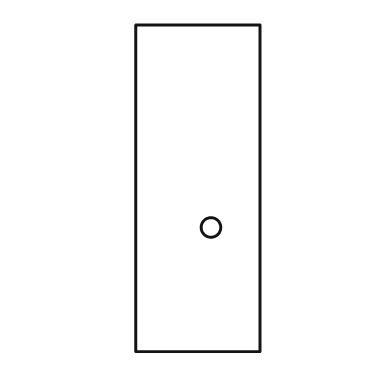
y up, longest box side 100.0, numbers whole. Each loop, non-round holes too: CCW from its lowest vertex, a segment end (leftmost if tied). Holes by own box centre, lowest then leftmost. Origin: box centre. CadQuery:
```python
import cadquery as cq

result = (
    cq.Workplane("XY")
    .moveTo(-19.0, -50.0)
    .lineTo(19.0, -50.0)
    .lineTo(19.0, 50.0)
    .lineTo(-19.0, 50.0)
    .close()
    .moveTo(4.0, -12.0)
    .circle(3.0)
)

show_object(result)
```